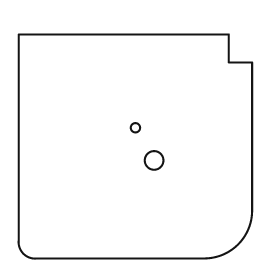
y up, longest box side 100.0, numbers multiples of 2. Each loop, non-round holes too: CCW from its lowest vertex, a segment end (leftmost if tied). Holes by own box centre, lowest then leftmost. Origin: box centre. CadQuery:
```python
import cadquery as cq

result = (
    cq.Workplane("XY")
    .moveTo(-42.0, -48.0)
    .lineTo(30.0, -48.0)
    .threePointArc((44.0, -42.0), (50.0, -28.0))
    .lineTo(50.0, 36.0)
    .lineTo(40.0, 36.0)
    .lineTo(40.0, 48.0)
    .lineTo(-50.0, 48.0)
    .lineTo(-50.0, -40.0)
    .threePointArc((-48.0, -46.0), (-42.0, -48.0))
    .close()
    .moveTo(8.0, -6.0)
    .circle(4.0)
    .moveTo(0.0, 8.0)
    .circle(2.0)
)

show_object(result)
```